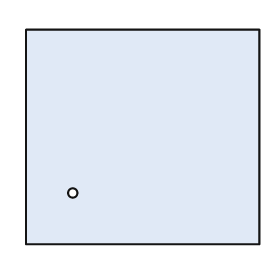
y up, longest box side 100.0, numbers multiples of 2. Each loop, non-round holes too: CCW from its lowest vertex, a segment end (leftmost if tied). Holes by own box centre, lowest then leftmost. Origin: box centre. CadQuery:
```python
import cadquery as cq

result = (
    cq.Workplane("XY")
    .moveTo(-50.0, -46.0)
    .lineTo(50.0, -46.0)
    .lineTo(50.0, 46.0)
    .lineTo(-50.0, 46.0)
    .close()
    .moveTo(-30.0, -24.0)
    .circle(2.0)
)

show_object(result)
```